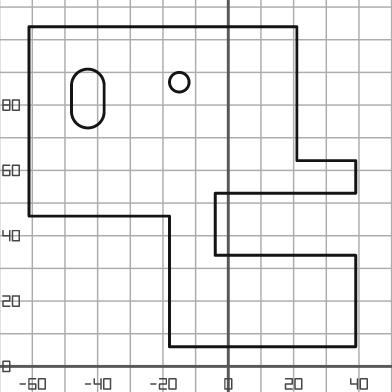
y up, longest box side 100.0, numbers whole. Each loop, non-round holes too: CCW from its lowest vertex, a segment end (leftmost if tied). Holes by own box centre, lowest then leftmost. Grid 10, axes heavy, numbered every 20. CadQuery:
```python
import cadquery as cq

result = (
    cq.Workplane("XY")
    .moveTo(-18.0, 6.0)
    .lineTo(39.0, 6.0)
    .lineTo(39.0, 34.0)
    .lineTo(-4.0, 34.0)
    .lineTo(-4.0, 53.0)
    .lineTo(39.0, 53.0)
    .lineTo(39.0, 63.0)
    .lineTo(21.0, 63.0)
    .lineTo(21.0, 104.0)
    .lineTo(-61.0, 104.0)
    .lineTo(-61.0, 46.0)
    .lineTo(-18.0, 46.0)
    .close()
    .moveTo(-48.0, 78.0)
    .threePointArc((-43.0, 73.0), (-38.0, 78.0))
    .lineTo(-38.0, 86.0)
    .threePointArc((-43.0, 91.0), (-48.0, 86.0))
    .close()
    .moveTo(-15.0, 87.0)
    .circle(3.0)
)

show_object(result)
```